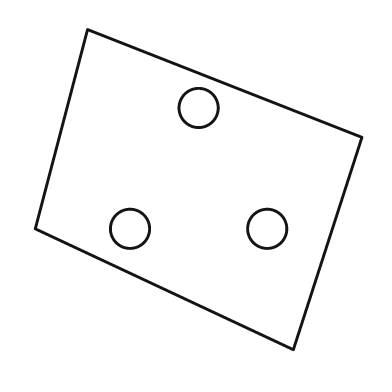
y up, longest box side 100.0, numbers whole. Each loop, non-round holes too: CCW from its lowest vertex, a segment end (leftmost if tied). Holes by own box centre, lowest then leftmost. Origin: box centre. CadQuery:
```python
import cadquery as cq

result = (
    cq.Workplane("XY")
    .moveTo(29.0, -49.0)
    .lineTo(50.0, 16.0)
    .lineTo(-34.0, 49.0)
    .lineTo(-50.0, -12.0)
    .close()
    .moveTo(-21.0, -12.0)
    .circle(6.0)
    .moveTo(21.0, -12.0)
    .circle(6.0)
    .moveTo(0.0, 25.0)
    .circle(6.0)
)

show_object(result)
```